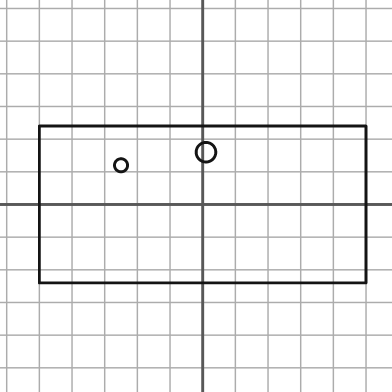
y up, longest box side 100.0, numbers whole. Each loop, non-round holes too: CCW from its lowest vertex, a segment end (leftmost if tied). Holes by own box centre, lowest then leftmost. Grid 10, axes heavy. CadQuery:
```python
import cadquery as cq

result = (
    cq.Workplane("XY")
    .moveTo(-50.0, -24.0)
    .lineTo(50.0, -24.0)
    .lineTo(50.0, 24.0)
    .lineTo(-50.0, 24.0)
    .close()
    .moveTo(-25.0, 12.0)
    .circle(2.0)
    .moveTo(1.0, 16.0)
    .circle(3.0)
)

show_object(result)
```